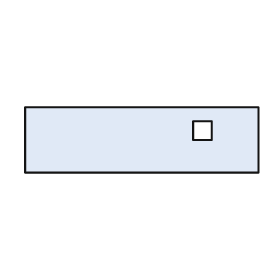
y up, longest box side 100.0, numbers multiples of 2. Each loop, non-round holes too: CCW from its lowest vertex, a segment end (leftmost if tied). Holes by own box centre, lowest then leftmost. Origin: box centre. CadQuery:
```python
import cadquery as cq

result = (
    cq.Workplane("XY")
    .moveTo(-50.0, -14.0)
    .lineTo(50.0, -14.0)
    .lineTo(50.0, 14.0)
    .lineTo(-50.0, 14.0)
    .close()
    .moveTo(22.0, 0.0)
    .lineTo(30.0, 0.0)
    .lineTo(30.0, 8.0)
    .lineTo(22.0, 8.0)
    .close()
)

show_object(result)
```